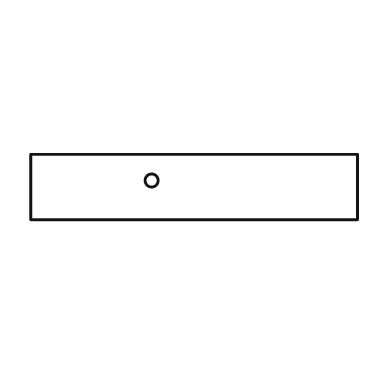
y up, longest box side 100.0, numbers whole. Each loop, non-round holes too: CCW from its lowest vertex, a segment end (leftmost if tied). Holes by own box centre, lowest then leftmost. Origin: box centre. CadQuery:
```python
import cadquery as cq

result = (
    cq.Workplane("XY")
    .moveTo(-50.0, -10.0)
    .lineTo(50.0, -10.0)
    .lineTo(50.0, 10.0)
    .lineTo(-50.0, 10.0)
    .close()
    .moveTo(-13.0, 2.0)
    .circle(2.0)
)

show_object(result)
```